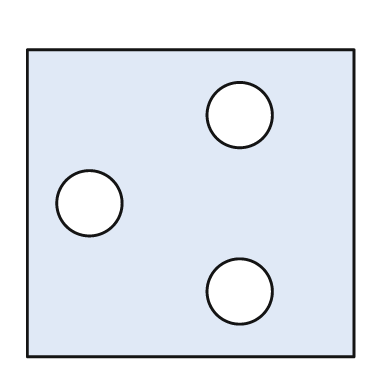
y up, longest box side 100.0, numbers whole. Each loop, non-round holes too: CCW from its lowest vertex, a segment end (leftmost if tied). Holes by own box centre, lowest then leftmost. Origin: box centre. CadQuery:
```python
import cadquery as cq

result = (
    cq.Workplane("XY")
    .moveTo(-50.0, -47.0)
    .lineTo(50.0, -47.0)
    .lineTo(50.0, 47.0)
    .lineTo(-50.0, 47.0)
    .close()
    .moveTo(15.0, -27.0)
    .circle(10.0)
    .moveTo(-31.0, 0.0)
    .circle(10.0)
    .moveTo(15.0, 27.0)
    .circle(10.0)
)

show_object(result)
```